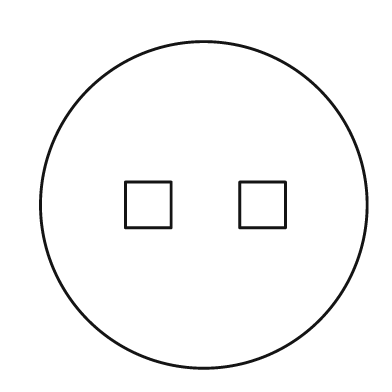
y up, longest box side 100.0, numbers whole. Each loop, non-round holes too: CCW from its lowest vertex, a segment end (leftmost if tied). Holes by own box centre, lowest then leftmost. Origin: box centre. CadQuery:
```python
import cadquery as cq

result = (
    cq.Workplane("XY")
    .moveTo(0.0, 0.0)
    .circle(50.0)
    .moveTo(-24.0, -7.0)
    .lineTo(-10.0, -7.0)
    .lineTo(-10.0, 7.0)
    .lineTo(-24.0, 7.0)
    .close()
    .moveTo(11.0, -7.0)
    .lineTo(25.0, -7.0)
    .lineTo(25.0, 7.0)
    .lineTo(11.0, 7.0)
    .close()
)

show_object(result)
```